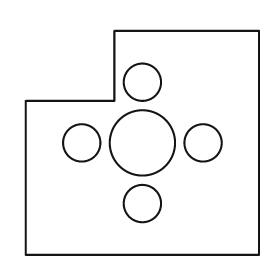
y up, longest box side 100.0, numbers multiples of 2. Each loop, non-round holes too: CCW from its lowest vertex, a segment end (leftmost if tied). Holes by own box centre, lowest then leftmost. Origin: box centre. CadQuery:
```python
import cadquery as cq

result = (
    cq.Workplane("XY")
    .moveTo(-50.0, -48.0)
    .lineTo(50.0, -48.0)
    .lineTo(50.0, 48.0)
    .lineTo(-12.0, 48.0)
    .lineTo(-12.0, 18.0)
    .lineTo(-50.0, 18.0)
    .close()
    .moveTo(0.0, -26.0)
    .circle(8.0)
    .moveTo(-26.0, 0.0)
    .circle(8.0)
    .moveTo(0.0, 0.0)
    .circle(14.0)
    .moveTo(26.0, 0.0)
    .circle(8.0)
    .moveTo(0.0, 26.0)
    .circle(8.0)
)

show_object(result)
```